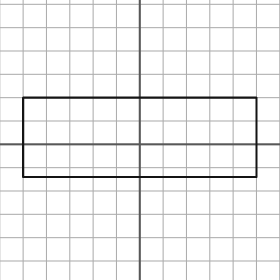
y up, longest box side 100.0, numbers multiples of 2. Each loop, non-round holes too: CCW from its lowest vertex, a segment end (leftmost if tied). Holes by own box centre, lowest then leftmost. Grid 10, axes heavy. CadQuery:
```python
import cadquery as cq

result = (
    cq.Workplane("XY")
    .moveTo(-50.0, -14.0)
    .lineTo(50.0, -14.0)
    .lineTo(50.0, 20.0)
    .lineTo(-50.0, 20.0)
    .close()
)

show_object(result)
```